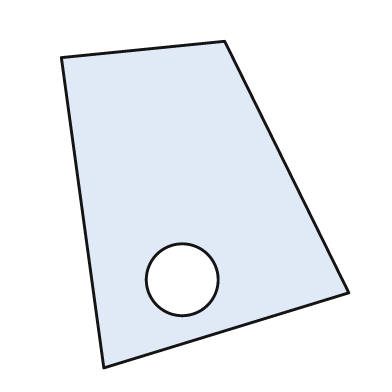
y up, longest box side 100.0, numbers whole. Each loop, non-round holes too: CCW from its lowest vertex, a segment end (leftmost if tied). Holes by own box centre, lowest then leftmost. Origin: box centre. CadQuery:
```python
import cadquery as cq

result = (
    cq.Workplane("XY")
    .moveTo(-31.0, -50.0)
    .lineTo(44.0, -27.0)
    .lineTo(6.0, 50.0)
    .lineTo(-44.0, 45.0)
    .close()
    .moveTo(-7.0, -23.0)
    .circle(11.0)
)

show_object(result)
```